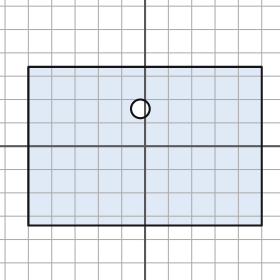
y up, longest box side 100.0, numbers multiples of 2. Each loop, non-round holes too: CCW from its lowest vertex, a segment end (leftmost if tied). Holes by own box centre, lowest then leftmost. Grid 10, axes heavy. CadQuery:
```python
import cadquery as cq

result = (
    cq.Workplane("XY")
    .moveTo(-50.0, -34.0)
    .lineTo(50.0, -34.0)
    .lineTo(50.0, 34.0)
    .lineTo(-50.0, 34.0)
    .close()
    .moveTo(-2.0, 16.0)
    .circle(4.0)
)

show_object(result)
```